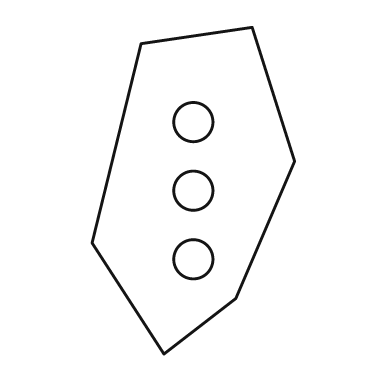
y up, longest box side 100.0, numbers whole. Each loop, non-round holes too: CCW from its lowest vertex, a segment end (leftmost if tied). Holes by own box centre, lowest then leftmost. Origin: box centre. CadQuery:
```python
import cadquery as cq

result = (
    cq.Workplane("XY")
    .moveTo(-9.0, -50.0)
    .lineTo(13.0, -33.0)
    .lineTo(31.0, 9.0)
    .lineTo(18.0, 50.0)
    .lineTo(-16.0, 45.0)
    .lineTo(-31.0, -16.0)
    .close()
    .moveTo(0.0, -21.0)
    .circle(6.0)
    .moveTo(0.0, 0.0)
    .circle(6.0)
    .moveTo(0.0, 21.0)
    .circle(6.0)
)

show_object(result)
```